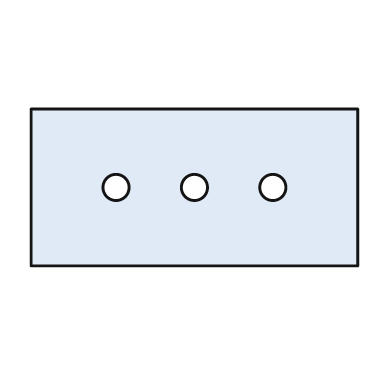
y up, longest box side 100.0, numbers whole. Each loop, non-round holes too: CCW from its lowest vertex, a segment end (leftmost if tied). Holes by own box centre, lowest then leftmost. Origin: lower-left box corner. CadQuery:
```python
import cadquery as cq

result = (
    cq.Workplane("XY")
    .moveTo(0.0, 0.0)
    .lineTo(100.0, 0.0)
    .lineTo(100.0, 48.0)
    .lineTo(0.0, 48.0)
    .close()
    .moveTo(26.0, 24.0)
    .circle(4.0)
    .moveTo(50.0, 24.0)
    .circle(4.0)
    .moveTo(74.0, 24.0)
    .circle(4.0)
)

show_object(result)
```